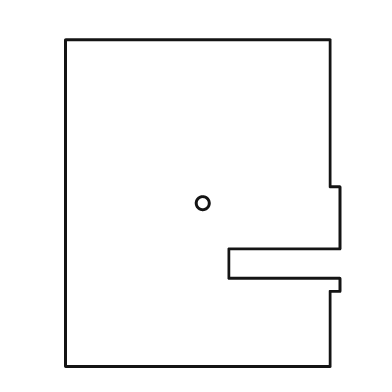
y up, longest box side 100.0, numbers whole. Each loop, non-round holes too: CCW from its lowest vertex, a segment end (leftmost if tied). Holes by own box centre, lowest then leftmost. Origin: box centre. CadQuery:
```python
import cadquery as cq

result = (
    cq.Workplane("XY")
    .moveTo(-42.0, -50.0)
    .lineTo(39.0, -50.0)
    .lineTo(39.0, -27.0)
    .lineTo(42.0, -27.0)
    .lineTo(42.0, -23.0)
    .lineTo(8.0, -23.0)
    .lineTo(8.0, -14.0)
    .lineTo(42.0, -14.0)
    .lineTo(42.0, 5.0)
    .lineTo(39.0, 5.0)
    .lineTo(39.0, 50.0)
    .lineTo(-42.0, 50.0)
    .close()
    .moveTo(0.0, 0.0)
    .circle(2.0)
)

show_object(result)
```